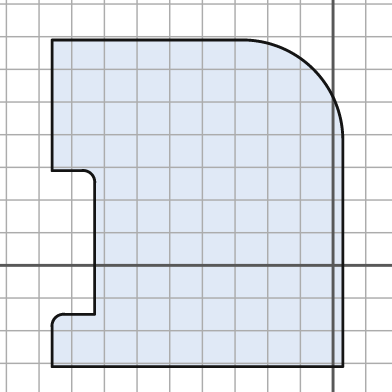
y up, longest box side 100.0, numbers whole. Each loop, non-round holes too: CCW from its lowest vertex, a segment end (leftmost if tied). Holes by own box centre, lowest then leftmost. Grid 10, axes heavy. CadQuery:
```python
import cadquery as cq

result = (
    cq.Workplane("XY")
    .moveTo(-86.0, -31.0)
    .lineTo(3.0, -31.0)
    .lineTo(3.0, 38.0)
    .threePointArc((-6.0, 60.0), (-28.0, 69.0))
    .lineTo(-86.0, 69.0)
    .lineTo(-86.0, 29.0)
    .lineTo(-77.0, 29.0)
    .threePointArc((-74.0, 28.0), (-73.0, 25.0))
    .lineTo(-73.0, -15.0)
    .lineTo(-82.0, -15.0)
    .threePointArc((-85.0, -16.0), (-86.0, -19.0))
    .close()
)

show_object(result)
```